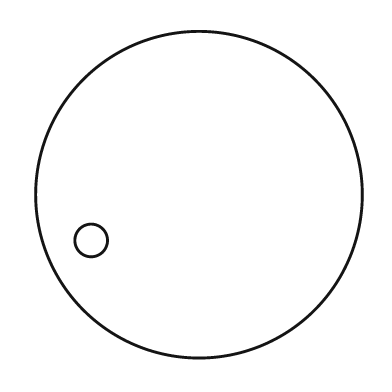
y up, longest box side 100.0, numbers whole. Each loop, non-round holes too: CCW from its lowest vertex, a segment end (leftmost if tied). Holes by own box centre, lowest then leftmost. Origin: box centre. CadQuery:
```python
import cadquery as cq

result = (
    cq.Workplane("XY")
    .moveTo(0.0, 0.0)
    .circle(50.0)
    .moveTo(-33.0, -14.0)
    .circle(5.0)
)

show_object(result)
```